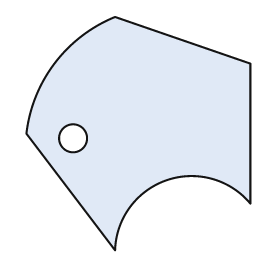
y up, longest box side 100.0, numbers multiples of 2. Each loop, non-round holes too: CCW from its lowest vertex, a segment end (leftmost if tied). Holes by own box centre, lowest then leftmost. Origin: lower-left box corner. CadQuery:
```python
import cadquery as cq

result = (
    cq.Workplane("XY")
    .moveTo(38.0, 0.0)
    .threePointArc((60.0, 30.0), (96.0, 20.0))
    .lineTo(96.0, 80.0)
    .lineTo(38.0, 100.0)
    .threePointArc((12.0, 80.0), (0.0, 50.0))
    .close()
    .moveTo(20.0, 48.0)
    .circle(6.0)
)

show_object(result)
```